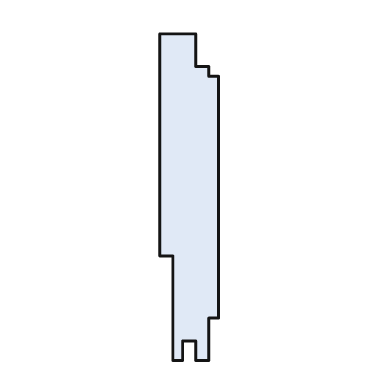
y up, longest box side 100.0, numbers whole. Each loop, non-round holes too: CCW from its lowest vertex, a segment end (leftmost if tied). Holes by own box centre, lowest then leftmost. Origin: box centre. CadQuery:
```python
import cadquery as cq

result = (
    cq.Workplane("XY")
    .moveTo(-5.0, -50.0)
    .lineTo(-2.0, -50.0)
    .lineTo(-2.0, -44.0)
    .lineTo(2.0, -44.0)
    .lineTo(2.0, -50.0)
    .lineTo(6.0, -50.0)
    .lineTo(6.0, -37.0)
    .lineTo(9.0, -37.0)
    .lineTo(9.0, 37.0)
    .lineTo(6.0, 37.0)
    .lineTo(6.0, 40.0)
    .lineTo(2.0, 40.0)
    .lineTo(2.0, 50.0)
    .lineTo(-9.0, 50.0)
    .lineTo(-9.0, -18.0)
    .lineTo(-5.0, -18.0)
    .close()
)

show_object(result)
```